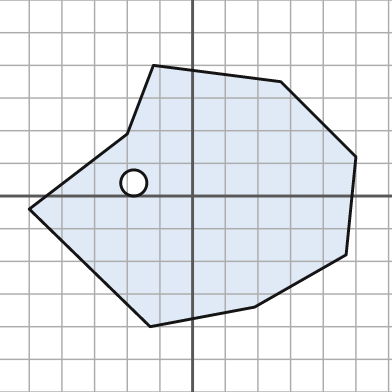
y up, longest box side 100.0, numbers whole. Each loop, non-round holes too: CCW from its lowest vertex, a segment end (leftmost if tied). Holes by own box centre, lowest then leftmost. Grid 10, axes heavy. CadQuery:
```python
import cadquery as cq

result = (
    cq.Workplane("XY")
    .moveTo(-13.0, -40.0)
    .lineTo(19.0, -34.0)
    .lineTo(47.0, -18.0)
    .lineTo(50.0, 12.0)
    .lineTo(27.0, 35.0)
    .lineTo(-12.0, 40.0)
    .lineTo(-20.0, 19.0)
    .lineTo(-50.0, -4.0)
    .close()
    .moveTo(-18.0, 4.0)
    .circle(4.0)
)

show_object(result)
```